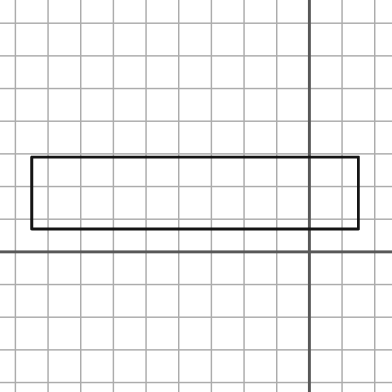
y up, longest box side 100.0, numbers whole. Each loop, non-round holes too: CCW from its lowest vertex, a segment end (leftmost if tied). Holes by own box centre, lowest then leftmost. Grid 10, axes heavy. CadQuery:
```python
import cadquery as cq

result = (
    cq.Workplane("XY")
    .moveTo(-85.0, 7.0)
    .lineTo(15.0, 7.0)
    .lineTo(15.0, 29.0)
    .lineTo(-85.0, 29.0)
    .close()
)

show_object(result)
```